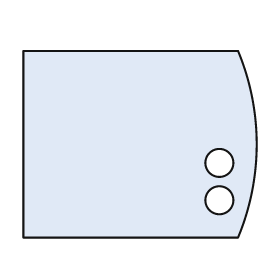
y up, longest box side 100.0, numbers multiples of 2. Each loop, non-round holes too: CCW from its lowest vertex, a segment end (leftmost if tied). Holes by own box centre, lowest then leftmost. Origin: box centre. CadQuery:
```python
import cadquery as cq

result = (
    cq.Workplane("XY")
    .moveTo(-50.0, -40.0)
    .lineTo(42.0, -40.0)
    .threePointArc((50.0, 0.0), (42.0, 40.0))
    .lineTo(-50.0, 40.0)
    .close()
    .moveTo(34.0, -24.0)
    .circle(6.0)
    .moveTo(34.0, -8.0)
    .circle(6.0)
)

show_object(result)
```